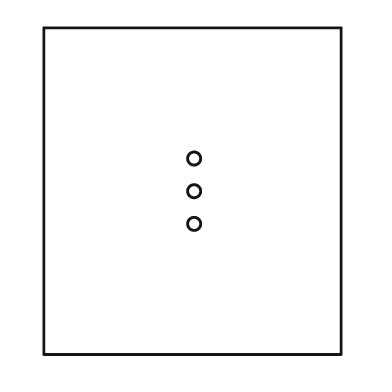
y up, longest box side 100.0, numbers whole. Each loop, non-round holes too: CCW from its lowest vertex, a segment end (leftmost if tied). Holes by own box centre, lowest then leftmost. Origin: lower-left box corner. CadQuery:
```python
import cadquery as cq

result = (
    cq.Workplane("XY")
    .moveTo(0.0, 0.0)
    .lineTo(91.0, 0.0)
    .lineTo(91.0, 100.0)
    .lineTo(0.0, 100.0)
    .close()
    .moveTo(46.0, 40.0)
    .circle(2.0)
    .moveTo(46.0, 50.0)
    .circle(2.0)
    .moveTo(46.0, 60.0)
    .circle(2.0)
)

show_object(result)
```